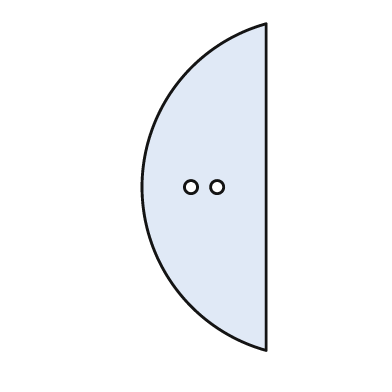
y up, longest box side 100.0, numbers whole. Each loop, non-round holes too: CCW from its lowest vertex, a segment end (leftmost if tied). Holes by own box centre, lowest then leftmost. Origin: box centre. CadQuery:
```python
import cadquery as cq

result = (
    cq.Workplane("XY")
    .moveTo(19.0, -50.0)
    .lineTo(19.0, 50.0)
    .threePointArc((-19.0, 0.0), (19.0, -50.0))
    .close()
    .moveTo(-4.0, 0.0)
    .circle(2.0)
    .moveTo(4.0, 0.0)
    .circle(2.0)
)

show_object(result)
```